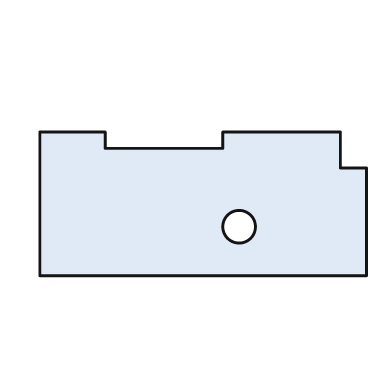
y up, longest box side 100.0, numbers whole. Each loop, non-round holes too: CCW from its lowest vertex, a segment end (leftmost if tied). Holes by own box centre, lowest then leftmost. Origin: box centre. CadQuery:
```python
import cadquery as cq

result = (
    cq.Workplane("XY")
    .moveTo(-50.0, -22.0)
    .lineTo(50.0, -22.0)
    .lineTo(50.0, 11.0)
    .lineTo(42.0, 11.0)
    .lineTo(42.0, 22.0)
    .lineTo(6.0, 22.0)
    .lineTo(6.0, 17.0)
    .lineTo(-30.0, 17.0)
    .lineTo(-30.0, 22.0)
    .lineTo(-50.0, 22.0)
    .close()
    .moveTo(11.0, -7.0)
    .circle(5.0)
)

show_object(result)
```